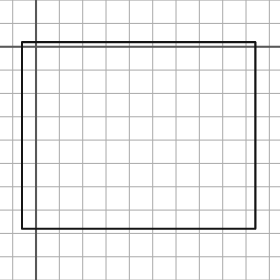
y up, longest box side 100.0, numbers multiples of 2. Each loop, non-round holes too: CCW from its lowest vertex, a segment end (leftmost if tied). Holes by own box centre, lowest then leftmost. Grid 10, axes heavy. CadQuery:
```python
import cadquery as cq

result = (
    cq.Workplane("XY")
    .moveTo(-6.0, -78.0)
    .lineTo(94.0, -78.0)
    .lineTo(94.0, 2.0)
    .lineTo(-6.0, 2.0)
    .close()
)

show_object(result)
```